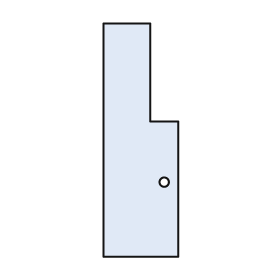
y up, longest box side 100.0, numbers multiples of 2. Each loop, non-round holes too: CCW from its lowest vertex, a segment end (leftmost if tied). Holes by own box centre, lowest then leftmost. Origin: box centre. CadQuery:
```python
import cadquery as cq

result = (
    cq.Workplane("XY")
    .moveTo(-16.0, -50.0)
    .lineTo(16.0, -50.0)
    .lineTo(16.0, 8.0)
    .lineTo(4.0, 8.0)
    .lineTo(4.0, 50.0)
    .lineTo(-16.0, 50.0)
    .close()
    .moveTo(10.0, -18.0)
    .circle(2.0)
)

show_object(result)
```